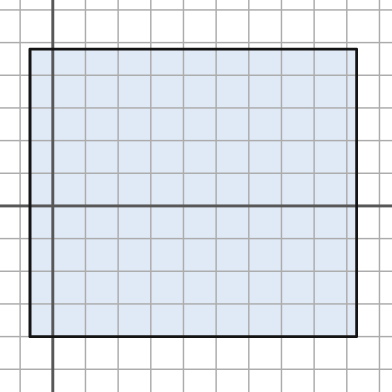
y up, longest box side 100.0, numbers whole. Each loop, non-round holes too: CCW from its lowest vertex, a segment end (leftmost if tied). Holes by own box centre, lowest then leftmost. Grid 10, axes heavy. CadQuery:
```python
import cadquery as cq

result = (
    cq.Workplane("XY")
    .moveTo(-7.0, -40.0)
    .lineTo(93.0, -40.0)
    .lineTo(93.0, 48.0)
    .lineTo(-7.0, 48.0)
    .close()
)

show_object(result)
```